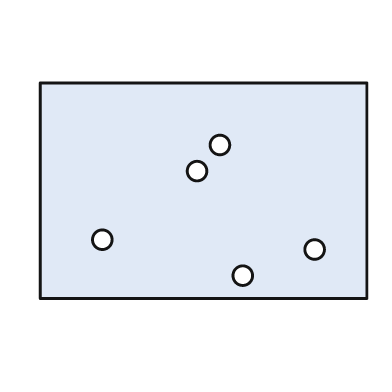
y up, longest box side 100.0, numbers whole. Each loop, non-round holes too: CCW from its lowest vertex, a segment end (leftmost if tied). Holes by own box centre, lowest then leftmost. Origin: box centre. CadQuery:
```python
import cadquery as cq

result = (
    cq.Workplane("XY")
    .moveTo(-50.0, -33.0)
    .lineTo(50.0, -33.0)
    .lineTo(50.0, 33.0)
    .lineTo(-50.0, 33.0)
    .close()
    .moveTo(12.0, -26.0)
    .circle(3.0)
    .moveTo(34.0, -18.0)
    .circle(3.0)
    .moveTo(-31.0, -15.0)
    .circle(3.0)
    .moveTo(-2.0, 6.0)
    .circle(3.0)
    .moveTo(5.0, 14.0)
    .circle(3.0)
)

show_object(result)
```